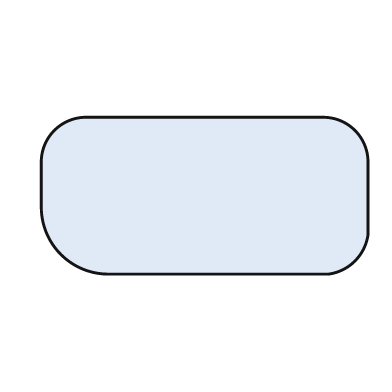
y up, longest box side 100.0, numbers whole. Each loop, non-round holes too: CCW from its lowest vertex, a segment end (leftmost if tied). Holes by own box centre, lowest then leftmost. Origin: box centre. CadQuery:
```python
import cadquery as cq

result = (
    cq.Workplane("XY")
    .moveTo(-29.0, -24.0)
    .lineTo(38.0, -24.0)
    .threePointArc((46.0, -20.0), (50.0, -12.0))
    .lineTo(50.0, 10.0)
    .threePointArc((46.0, 20.0), (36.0, 24.0))
    .lineTo(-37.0, 24.0)
    .threePointArc((-46.0, 20.0), (-50.0, 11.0))
    .lineTo(-50.0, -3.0)
    .threePointArc((-44.0, -18.0), (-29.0, -24.0))
    .close()
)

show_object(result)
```